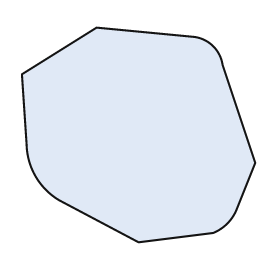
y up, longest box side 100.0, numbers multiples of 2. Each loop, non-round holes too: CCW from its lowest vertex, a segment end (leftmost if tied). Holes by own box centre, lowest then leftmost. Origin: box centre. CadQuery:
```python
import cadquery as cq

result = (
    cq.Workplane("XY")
    .moveTo(0.0, -46.0)
    .lineTo(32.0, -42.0)
    .threePointArc((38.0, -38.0), (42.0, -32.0))
    .lineTo(50.0, -12.0)
    .lineTo(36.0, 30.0)
    .threePointArc((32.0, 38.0), (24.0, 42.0))
    .lineTo(-18.0, 46.0)
    .lineTo(-50.0, 26.0)
    .lineTo(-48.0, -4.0)
    .threePointArc((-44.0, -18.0), (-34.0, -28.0))
    .close()
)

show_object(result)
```